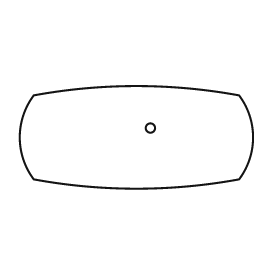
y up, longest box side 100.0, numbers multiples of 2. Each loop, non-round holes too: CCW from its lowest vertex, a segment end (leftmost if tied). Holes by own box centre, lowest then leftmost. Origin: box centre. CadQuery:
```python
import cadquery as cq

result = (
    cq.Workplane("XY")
    .moveTo(-44.0, -18.0)
    .threePointArc((0.0, -22.0), (44.0, -18.0))
    .threePointArc((50.0, 0.0), (44.0, 18.0))
    .threePointArc((0.0, 22.0), (-44.0, 18.0))
    .threePointArc((-50.0, 0.0), (-44.0, -18.0))
    .close()
    .moveTo(6.0, 4.0)
    .circle(2.0)
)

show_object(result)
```